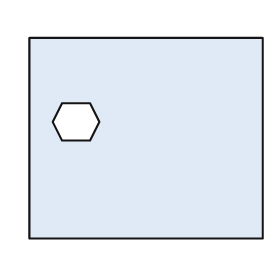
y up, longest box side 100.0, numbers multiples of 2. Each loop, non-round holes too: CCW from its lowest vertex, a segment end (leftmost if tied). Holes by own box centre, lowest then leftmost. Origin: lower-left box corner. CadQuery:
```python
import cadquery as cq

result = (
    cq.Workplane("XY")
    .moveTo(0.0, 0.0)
    .lineTo(100.0, 0.0)
    .lineTo(100.0, 86.0)
    .lineTo(0.0, 86.0)
    .close()
    .moveTo(14.0, 42.0)
    .lineTo(26.0, 42.0)
    .lineTo(30.0, 50.0)
    .lineTo(26.0, 58.0)
    .lineTo(14.0, 58.0)
    .lineTo(10.0, 50.0)
    .close()
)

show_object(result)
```